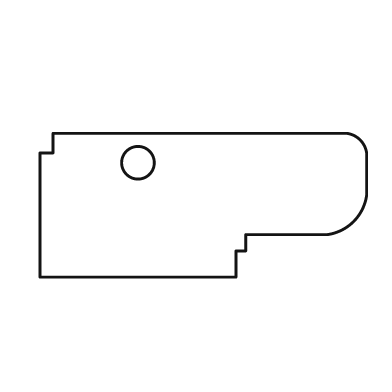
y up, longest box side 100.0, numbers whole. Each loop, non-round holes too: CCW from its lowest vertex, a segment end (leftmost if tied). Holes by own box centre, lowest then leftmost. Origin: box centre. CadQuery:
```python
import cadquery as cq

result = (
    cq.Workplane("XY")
    .moveTo(-50.0, -22.0)
    .lineTo(10.0, -22.0)
    .lineTo(10.0, -14.0)
    .lineTo(13.0, -14.0)
    .lineTo(13.0, -9.0)
    .lineTo(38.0, -9.0)
    .threePointArc((46.0, -5.0), (50.0, 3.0))
    .lineTo(50.0, 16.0)
    .threePointArc((48.0, 20.0), (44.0, 22.0))
    .lineTo(-46.0, 22.0)
    .lineTo(-46.0, 16.0)
    .lineTo(-50.0, 16.0)
    .close()
    .moveTo(-20.0, 13.0)
    .circle(5.0)
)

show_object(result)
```